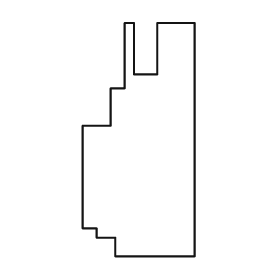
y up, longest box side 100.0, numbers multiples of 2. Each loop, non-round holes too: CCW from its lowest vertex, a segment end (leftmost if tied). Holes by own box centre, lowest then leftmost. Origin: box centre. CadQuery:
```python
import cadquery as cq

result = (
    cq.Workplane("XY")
    .moveTo(-10.0, -50.0)
    .lineTo(24.0, -50.0)
    .lineTo(24.0, 50.0)
    .lineTo(8.0, 50.0)
    .lineTo(8.0, 28.0)
    .lineTo(-2.0, 28.0)
    .lineTo(-2.0, 50.0)
    .lineTo(-6.0, 50.0)
    .lineTo(-6.0, 22.0)
    .lineTo(-12.0, 22.0)
    .lineTo(-12.0, 6.0)
    .lineTo(-24.0, 6.0)
    .lineTo(-24.0, -38.0)
    .lineTo(-18.0, -38.0)
    .lineTo(-18.0, -42.0)
    .lineTo(-10.0, -42.0)
    .close()
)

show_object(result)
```